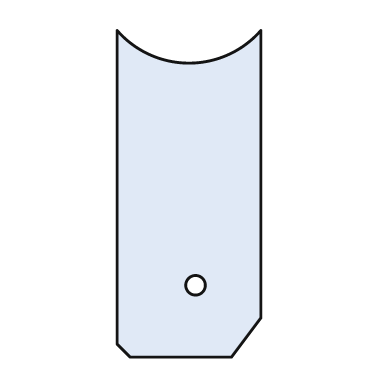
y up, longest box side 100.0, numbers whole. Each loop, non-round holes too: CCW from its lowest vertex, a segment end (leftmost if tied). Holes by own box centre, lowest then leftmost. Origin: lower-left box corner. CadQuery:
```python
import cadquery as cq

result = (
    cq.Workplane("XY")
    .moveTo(4.0, 0.0)
    .lineTo(35.0, 0.0)
    .lineTo(44.0, 12.0)
    .lineTo(44.0, 100.0)
    .threePointArc((22.0, 90.0), (0.0, 100.0))
    .lineTo(0.0, 4.0)
    .close()
    .moveTo(24.0, 22.0)
    .circle(3.0)
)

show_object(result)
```